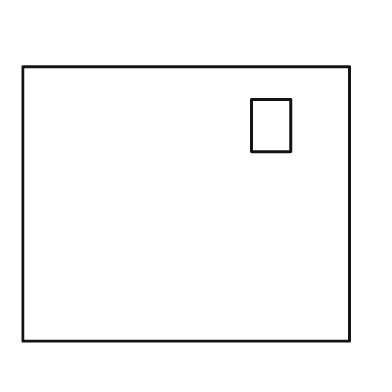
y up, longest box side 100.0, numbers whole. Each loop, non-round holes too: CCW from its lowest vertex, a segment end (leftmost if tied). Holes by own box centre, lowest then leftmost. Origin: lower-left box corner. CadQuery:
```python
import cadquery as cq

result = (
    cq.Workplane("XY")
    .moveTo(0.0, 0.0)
    .lineTo(100.0, 0.0)
    .lineTo(100.0, 84.0)
    .lineTo(0.0, 84.0)
    .close()
    .moveTo(70.0, 58.0)
    .lineTo(82.0, 58.0)
    .lineTo(82.0, 74.0)
    .lineTo(70.0, 74.0)
    .close()
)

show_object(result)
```